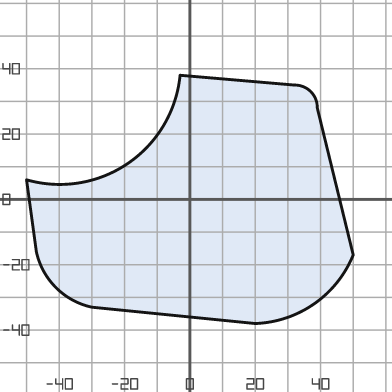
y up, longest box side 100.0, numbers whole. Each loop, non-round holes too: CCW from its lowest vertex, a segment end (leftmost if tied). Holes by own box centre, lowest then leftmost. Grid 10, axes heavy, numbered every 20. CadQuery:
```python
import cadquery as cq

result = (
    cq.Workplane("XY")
    .moveTo(20.0, -38.0)
    .threePointArc((38.0, -32.0), (50.0, -17.0))
    .lineTo(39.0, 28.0)
    .threePointArc((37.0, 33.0), (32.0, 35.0))
    .lineTo(-3.0, 38.0)
    .threePointArc((-19.0, 11.0), (-50.0, 6.0))
    .lineTo(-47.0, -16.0)
    .threePointArc((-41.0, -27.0), (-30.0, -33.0))
    .close()
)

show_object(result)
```